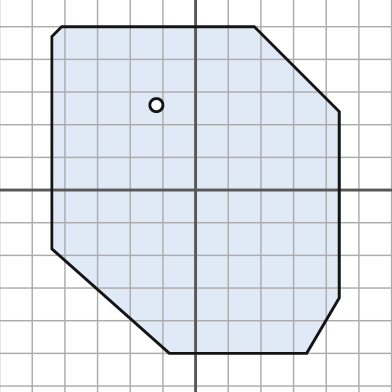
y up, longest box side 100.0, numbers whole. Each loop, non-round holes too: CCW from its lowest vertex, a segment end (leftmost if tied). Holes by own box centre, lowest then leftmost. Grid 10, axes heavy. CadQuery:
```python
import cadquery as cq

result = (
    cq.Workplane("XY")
    .moveTo(-8.0, -50.0)
    .lineTo(34.0, -50.0)
    .lineTo(44.0, -33.0)
    .lineTo(44.0, 24.0)
    .lineTo(18.0, 50.0)
    .lineTo(-41.0, 50.0)
    .lineTo(-44.0, 47.0)
    .lineTo(-44.0, -18.0)
    .close()
    .moveTo(-12.0, 26.0)
    .circle(2.0)
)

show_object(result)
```